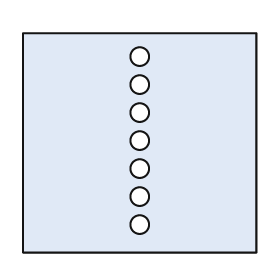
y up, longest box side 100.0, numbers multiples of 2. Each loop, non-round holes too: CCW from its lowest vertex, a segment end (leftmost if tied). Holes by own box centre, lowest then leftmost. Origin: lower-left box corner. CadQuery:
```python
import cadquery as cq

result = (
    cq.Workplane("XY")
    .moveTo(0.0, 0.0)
    .lineTo(100.0, 0.0)
    .lineTo(100.0, 94.0)
    .lineTo(0.0, 94.0)
    .close()
    .moveTo(50.0, 12.0)
    .circle(4.0)
    .moveTo(50.0, 24.0)
    .circle(4.0)
    .moveTo(50.0, 36.0)
    .circle(4.0)
    .moveTo(50.0, 48.0)
    .circle(4.0)
    .moveTo(50.0, 60.0)
    .circle(4.0)
    .moveTo(50.0, 72.0)
    .circle(4.0)
    .moveTo(50.0, 84.0)
    .circle(4.0)
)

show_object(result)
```